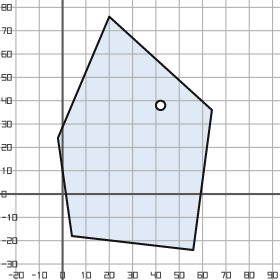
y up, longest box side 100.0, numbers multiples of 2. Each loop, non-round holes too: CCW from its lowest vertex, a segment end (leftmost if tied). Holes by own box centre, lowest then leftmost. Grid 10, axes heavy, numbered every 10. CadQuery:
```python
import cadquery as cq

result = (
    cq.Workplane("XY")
    .moveTo(56.0, -24.0)
    .lineTo(64.0, 36.0)
    .lineTo(20.0, 76.0)
    .lineTo(-2.0, 24.0)
    .lineTo(4.0, -18.0)
    .close()
    .moveTo(42.0, 38.0)
    .circle(2.0)
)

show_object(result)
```